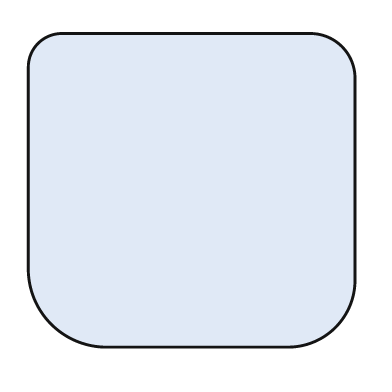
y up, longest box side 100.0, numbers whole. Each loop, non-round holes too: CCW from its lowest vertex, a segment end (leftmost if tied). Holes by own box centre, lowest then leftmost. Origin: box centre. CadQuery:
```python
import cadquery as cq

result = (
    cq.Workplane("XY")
    .moveTo(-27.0, -48.0)
    .lineTo(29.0, -48.0)
    .threePointArc((44.0, -42.0), (50.0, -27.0))
    .lineTo(50.0, 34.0)
    .threePointArc((46.0, 44.0), (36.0, 48.0))
    .lineTo(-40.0, 48.0)
    .threePointArc((-47.0, 45.0), (-50.0, 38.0))
    .lineTo(-50.0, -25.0)
    .threePointArc((-43.0, -41.0), (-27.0, -48.0))
    .close()
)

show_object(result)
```